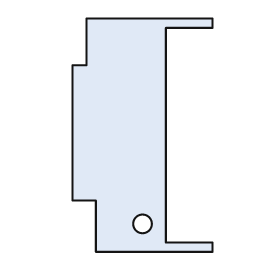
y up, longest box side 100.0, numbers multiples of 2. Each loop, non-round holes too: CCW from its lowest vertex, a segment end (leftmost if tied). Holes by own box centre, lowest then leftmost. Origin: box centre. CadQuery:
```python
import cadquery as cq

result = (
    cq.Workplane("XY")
    .moveTo(-20.0, -50.0)
    .lineTo(30.0, -50.0)
    .lineTo(30.0, -46.0)
    .lineTo(10.0, -46.0)
    .lineTo(10.0, 46.0)
    .lineTo(30.0, 46.0)
    .lineTo(30.0, 50.0)
    .lineTo(-24.0, 50.0)
    .lineTo(-24.0, 30.0)
    .lineTo(-30.0, 30.0)
    .lineTo(-30.0, -28.0)
    .lineTo(-20.0, -28.0)
    .close()
    .moveTo(0.0, -38.0)
    .circle(4.0)
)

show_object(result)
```